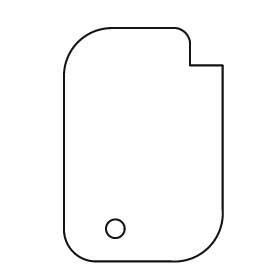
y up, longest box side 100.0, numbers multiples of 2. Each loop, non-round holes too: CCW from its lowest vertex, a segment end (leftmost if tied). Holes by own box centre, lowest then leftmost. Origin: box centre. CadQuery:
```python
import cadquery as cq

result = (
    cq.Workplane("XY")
    .moveTo(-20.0, -50.0)
    .lineTo(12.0, -50.0)
    .threePointArc((28.0, -44.0), (34.0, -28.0))
    .lineTo(34.0, 34.0)
    .lineTo(20.0, 34.0)
    .lineTo(20.0, 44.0)
    .threePointArc((18.0, 48.0), (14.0, 50.0))
    .lineTo(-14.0, 50.0)
    .threePointArc((-28.0, 44.0), (-34.0, 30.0))
    .lineTo(-34.0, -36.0)
    .threePointArc((-30.0, -46.0), (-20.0, -50.0))
    .close()
    .moveTo(-12.0, -36.0)
    .circle(4.0)
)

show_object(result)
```